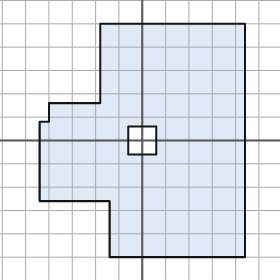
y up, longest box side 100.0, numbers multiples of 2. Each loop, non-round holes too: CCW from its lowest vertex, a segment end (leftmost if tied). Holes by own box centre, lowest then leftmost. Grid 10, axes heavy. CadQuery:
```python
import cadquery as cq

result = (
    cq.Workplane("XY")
    .moveTo(-14.0, -50.0)
    .lineTo(44.0, -50.0)
    .lineTo(44.0, 50.0)
    .lineTo(-18.0, 50.0)
    .lineTo(-18.0, 16.0)
    .lineTo(-40.0, 16.0)
    .lineTo(-40.0, 8.0)
    .lineTo(-44.0, 8.0)
    .lineTo(-44.0, -26.0)
    .lineTo(-14.0, -26.0)
    .close()
    .moveTo(-6.0, -6.0)
    .lineTo(6.0, -6.0)
    .lineTo(6.0, 6.0)
    .lineTo(-6.0, 6.0)
    .close()
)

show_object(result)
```